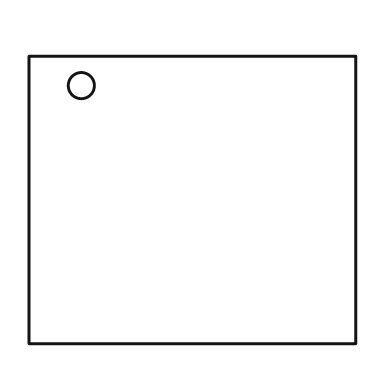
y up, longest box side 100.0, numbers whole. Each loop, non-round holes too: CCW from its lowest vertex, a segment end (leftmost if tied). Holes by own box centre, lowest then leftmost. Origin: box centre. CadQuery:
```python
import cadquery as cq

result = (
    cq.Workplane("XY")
    .moveTo(-50.0, -44.0)
    .lineTo(50.0, -44.0)
    .lineTo(50.0, 44.0)
    .lineTo(-50.0, 44.0)
    .close()
    .moveTo(-34.0, 35.0)
    .circle(4.0)
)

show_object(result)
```